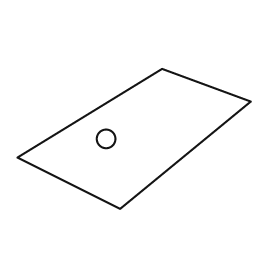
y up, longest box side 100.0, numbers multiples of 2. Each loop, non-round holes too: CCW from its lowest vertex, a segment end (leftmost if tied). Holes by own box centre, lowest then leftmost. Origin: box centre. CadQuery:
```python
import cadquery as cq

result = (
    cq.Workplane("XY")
    .moveTo(-6.0, -30.0)
    .lineTo(50.0, 16.0)
    .lineTo(12.0, 30.0)
    .lineTo(-50.0, -8.0)
    .close()
    .moveTo(-12.0, 0.0)
    .circle(4.0)
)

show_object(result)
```